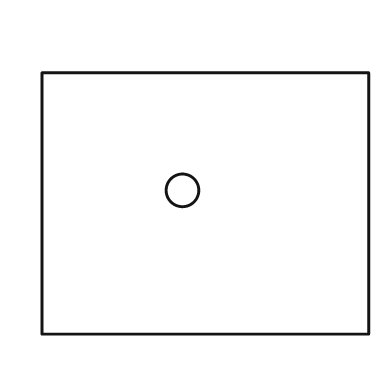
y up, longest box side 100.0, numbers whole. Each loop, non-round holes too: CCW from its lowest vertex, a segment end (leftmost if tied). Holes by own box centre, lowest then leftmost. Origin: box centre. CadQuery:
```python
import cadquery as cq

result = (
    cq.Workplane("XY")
    .moveTo(-50.0, -40.0)
    .lineTo(50.0, -40.0)
    .lineTo(50.0, 40.0)
    .lineTo(-50.0, 40.0)
    .close()
    .moveTo(-7.0, 4.0)
    .circle(5.0)
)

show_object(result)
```